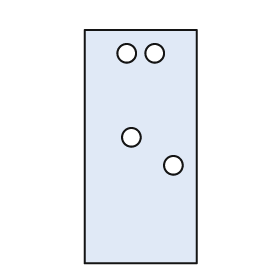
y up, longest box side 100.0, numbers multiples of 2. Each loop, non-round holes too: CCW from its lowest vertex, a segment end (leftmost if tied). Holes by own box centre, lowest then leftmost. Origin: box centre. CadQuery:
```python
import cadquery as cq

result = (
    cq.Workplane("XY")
    .moveTo(-24.0, -50.0)
    .lineTo(24.0, -50.0)
    .lineTo(24.0, 50.0)
    .lineTo(-24.0, 50.0)
    .close()
    .moveTo(14.0, -8.0)
    .circle(4.0)
    .moveTo(-4.0, 4.0)
    .circle(4.0)
    .moveTo(-6.0, 40.0)
    .circle(4.0)
    .moveTo(6.0, 40.0)
    .circle(4.0)
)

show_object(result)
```